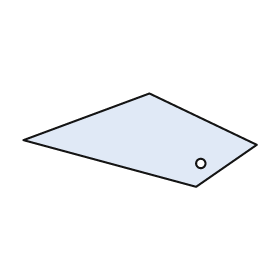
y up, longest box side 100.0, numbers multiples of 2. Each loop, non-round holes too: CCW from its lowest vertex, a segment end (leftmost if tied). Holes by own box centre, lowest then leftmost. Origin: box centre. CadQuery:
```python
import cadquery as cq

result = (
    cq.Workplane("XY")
    .moveTo(24.0, -20.0)
    .lineTo(50.0, -2.0)
    .lineTo(4.0, 20.0)
    .lineTo(-50.0, 0.0)
    .close()
    .moveTo(26.0, -10.0)
    .circle(2.0)
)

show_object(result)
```